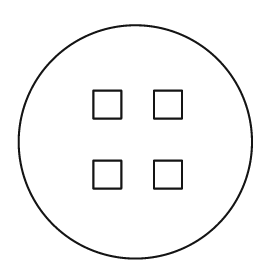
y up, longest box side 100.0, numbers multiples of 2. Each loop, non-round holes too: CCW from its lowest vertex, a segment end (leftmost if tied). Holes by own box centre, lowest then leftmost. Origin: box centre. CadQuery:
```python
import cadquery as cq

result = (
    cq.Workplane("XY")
    .moveTo(0.0, 0.0)
    .circle(50.0)
    .moveTo(-18.0, -20.0)
    .lineTo(-6.0, -20.0)
    .lineTo(-6.0, -8.0)
    .lineTo(-18.0, -8.0)
    .close()
    .moveTo(8.0, -20.0)
    .lineTo(20.0, -20.0)
    .lineTo(20.0, -8.0)
    .lineTo(8.0, -8.0)
    .close()
    .moveTo(-18.0, 10.0)
    .lineTo(-6.0, 10.0)
    .lineTo(-6.0, 22.0)
    .lineTo(-18.0, 22.0)
    .close()
    .moveTo(8.0, 10.0)
    .lineTo(20.0, 10.0)
    .lineTo(20.0, 22.0)
    .lineTo(8.0, 22.0)
    .close()
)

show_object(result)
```